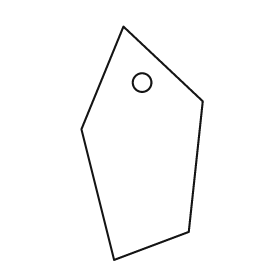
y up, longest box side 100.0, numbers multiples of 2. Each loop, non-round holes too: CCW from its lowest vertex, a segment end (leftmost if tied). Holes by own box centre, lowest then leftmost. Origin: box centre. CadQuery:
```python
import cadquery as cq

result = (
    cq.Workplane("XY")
    .moveTo(-12.0, -50.0)
    .lineTo(20.0, -38.0)
    .lineTo(26.0, 18.0)
    .lineTo(-8.0, 50.0)
    .lineTo(-26.0, 6.0)
    .close()
    .moveTo(0.0, 26.0)
    .circle(4.0)
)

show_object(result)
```